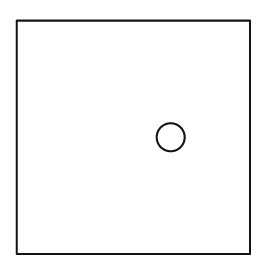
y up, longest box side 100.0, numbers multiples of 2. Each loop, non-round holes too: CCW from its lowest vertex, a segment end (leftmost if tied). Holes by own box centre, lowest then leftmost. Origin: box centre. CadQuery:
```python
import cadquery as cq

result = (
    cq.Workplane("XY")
    .moveTo(-50.0, -50.0)
    .lineTo(50.0, -50.0)
    .lineTo(50.0, 50.0)
    .lineTo(-50.0, 50.0)
    .close()
    .moveTo(16.0, 0.0)
    .circle(6.0)
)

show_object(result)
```